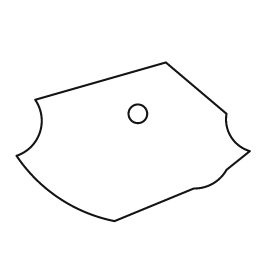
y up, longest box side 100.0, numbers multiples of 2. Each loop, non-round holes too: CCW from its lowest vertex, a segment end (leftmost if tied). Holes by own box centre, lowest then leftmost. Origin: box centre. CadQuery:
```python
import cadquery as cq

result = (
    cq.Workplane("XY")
    .moveTo(-8.0, -34.0)
    .lineTo(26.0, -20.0)
    .threePointArc((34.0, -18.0), (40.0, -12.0))
    .lineTo(50.0, -4.0)
    .threePointArc((42.0, 2.0), (40.0, 12.0))
    .lineTo(14.0, 34.0)
    .lineTo(-42.0, 18.0)
    .threePointArc((-40.0, 4.0), (-50.0, -6.0))
    .threePointArc((-32.0, -24.0), (-8.0, -34.0))
    .close()
    .moveTo(2.0, 12.0)
    .circle(4.0)
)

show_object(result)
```